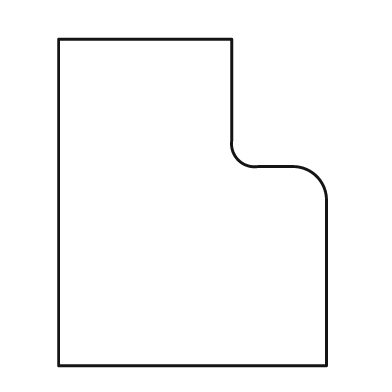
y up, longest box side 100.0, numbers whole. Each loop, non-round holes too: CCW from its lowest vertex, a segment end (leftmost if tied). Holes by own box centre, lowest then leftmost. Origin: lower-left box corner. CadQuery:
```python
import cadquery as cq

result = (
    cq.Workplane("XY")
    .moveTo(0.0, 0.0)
    .lineTo(82.0, 0.0)
    .lineTo(82.0, 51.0)
    .threePointArc((79.0, 58.0), (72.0, 61.0))
    .lineTo(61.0, 61.0)
    .threePointArc((55.0, 63.0), (53.0, 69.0))
    .lineTo(53.0, 100.0)
    .lineTo(0.0, 100.0)
    .close()
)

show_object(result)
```